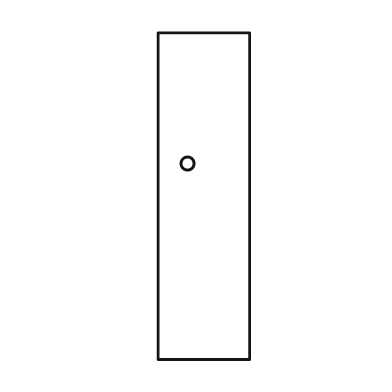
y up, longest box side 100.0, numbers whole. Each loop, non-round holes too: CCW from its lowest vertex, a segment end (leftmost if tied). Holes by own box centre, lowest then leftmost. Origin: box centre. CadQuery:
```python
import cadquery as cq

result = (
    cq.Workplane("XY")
    .moveTo(-14.0, -50.0)
    .lineTo(14.0, -50.0)
    .lineTo(14.0, 50.0)
    .lineTo(-14.0, 50.0)
    .close()
    .moveTo(-5.0, 10.0)
    .circle(2.0)
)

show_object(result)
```